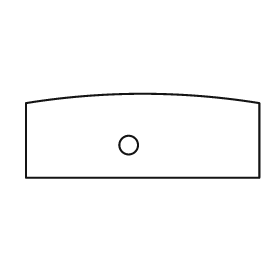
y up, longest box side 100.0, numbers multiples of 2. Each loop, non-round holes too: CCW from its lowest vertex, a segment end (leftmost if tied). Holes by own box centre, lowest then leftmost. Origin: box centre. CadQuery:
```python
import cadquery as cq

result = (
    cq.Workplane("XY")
    .moveTo(-50.0, -18.0)
    .lineTo(50.0, -18.0)
    .lineTo(50.0, 14.0)
    .threePointArc((0.0, 18.0), (-50.0, 14.0))
    .close()
    .moveTo(-6.0, -4.0)
    .circle(4.0)
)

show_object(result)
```